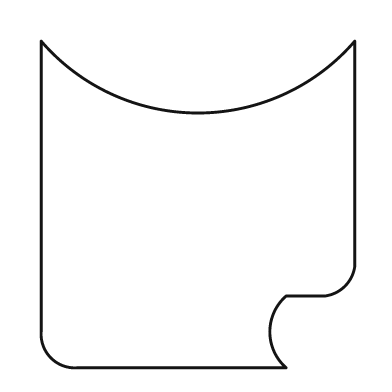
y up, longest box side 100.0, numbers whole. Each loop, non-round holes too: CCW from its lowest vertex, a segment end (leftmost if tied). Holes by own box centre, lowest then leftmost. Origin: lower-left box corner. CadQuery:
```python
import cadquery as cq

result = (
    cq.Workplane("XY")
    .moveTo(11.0, 0.0)
    .lineTo(75.0, 0.0)
    .threePointArc((70.0, 11.0), (75.0, 22.0))
    .lineTo(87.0, 22.0)
    .threePointArc((93.0, 25.0), (96.0, 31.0))
    .lineTo(96.0, 100.0)
    .threePointArc((48.0, 78.0), (0.0, 100.0))
    .lineTo(0.0, 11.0)
    .threePointArc((3.0, 3.0), (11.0, 0.0))
    .close()
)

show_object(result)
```